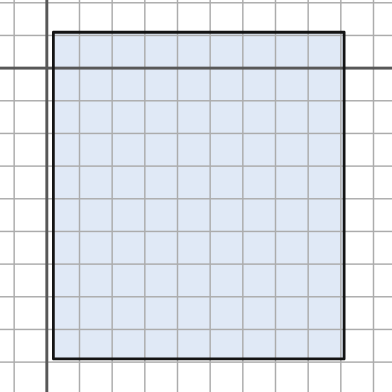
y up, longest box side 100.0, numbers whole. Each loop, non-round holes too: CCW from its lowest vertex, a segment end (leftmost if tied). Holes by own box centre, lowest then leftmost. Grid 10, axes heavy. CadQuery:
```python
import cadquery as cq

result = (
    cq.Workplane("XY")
    .moveTo(2.0, -89.0)
    .lineTo(91.0, -89.0)
    .lineTo(91.0, 11.0)
    .lineTo(2.0, 11.0)
    .close()
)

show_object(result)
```